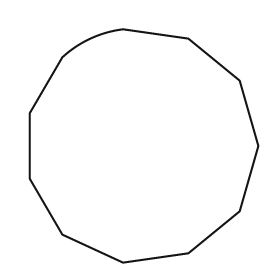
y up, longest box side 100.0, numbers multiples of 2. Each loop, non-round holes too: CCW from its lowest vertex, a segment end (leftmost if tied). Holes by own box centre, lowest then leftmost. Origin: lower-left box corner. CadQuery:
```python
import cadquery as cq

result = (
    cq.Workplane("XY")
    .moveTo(40.0, 0.0)
    .lineTo(68.0, 4.0)
    .lineTo(90.0, 22.0)
    .lineTo(98.0, 50.0)
    .lineTo(90.0, 78.0)
    .lineTo(68.0, 96.0)
    .lineTo(40.0, 100.0)
    .threePointArc((26.0, 96.0), (14.0, 88.0))
    .lineTo(0.0, 64.0)
    .lineTo(0.0, 36.0)
    .lineTo(14.0, 12.0)
    .close()
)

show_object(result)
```